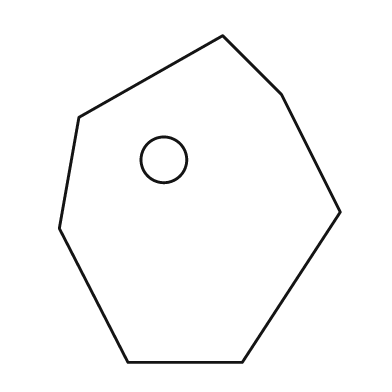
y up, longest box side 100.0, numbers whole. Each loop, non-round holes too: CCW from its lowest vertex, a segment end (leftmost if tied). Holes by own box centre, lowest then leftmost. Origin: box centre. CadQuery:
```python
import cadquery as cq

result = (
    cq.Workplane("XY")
    .moveTo(-22.0, -50.0)
    .lineTo(13.0, -50.0)
    .lineTo(43.0, -4.0)
    .lineTo(25.0, 32.0)
    .lineTo(7.0, 50.0)
    .lineTo(-37.0, 25.0)
    .lineTo(-43.0, -9.0)
    .close()
    .moveTo(-11.0, 12.0)
    .circle(7.0)
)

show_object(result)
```